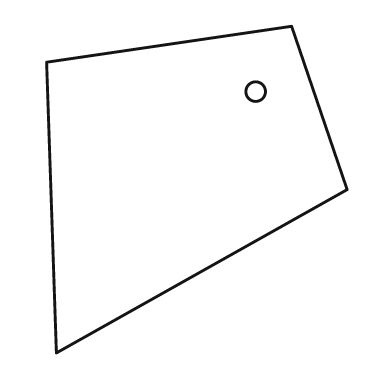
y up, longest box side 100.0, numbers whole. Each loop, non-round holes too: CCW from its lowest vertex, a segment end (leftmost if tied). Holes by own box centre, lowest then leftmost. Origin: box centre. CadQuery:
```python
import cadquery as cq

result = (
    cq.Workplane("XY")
    .moveTo(-43.0, -50.0)
    .lineTo(46.0, 0.0)
    .lineTo(29.0, 50.0)
    .lineTo(-46.0, 39.0)
    .close()
    .moveTo(18.0, 30.0)
    .circle(3.0)
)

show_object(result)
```